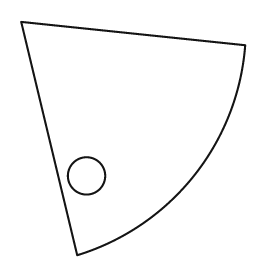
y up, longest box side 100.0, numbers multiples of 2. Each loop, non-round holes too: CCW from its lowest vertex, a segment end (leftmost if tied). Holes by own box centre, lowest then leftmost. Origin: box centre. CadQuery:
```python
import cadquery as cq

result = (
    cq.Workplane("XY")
    .moveTo(-24.0, -50.0)
    .threePointArc((26.0, -16.0), (48.0, 40.0))
    .lineTo(-48.0, 50.0)
    .close()
    .moveTo(-20.0, -16.0)
    .circle(8.0)
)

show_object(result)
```